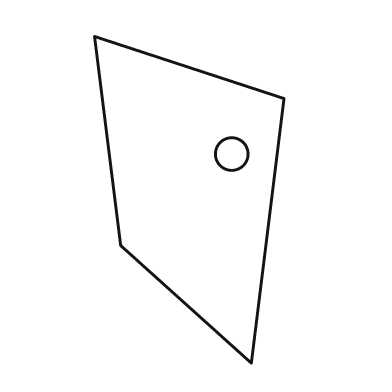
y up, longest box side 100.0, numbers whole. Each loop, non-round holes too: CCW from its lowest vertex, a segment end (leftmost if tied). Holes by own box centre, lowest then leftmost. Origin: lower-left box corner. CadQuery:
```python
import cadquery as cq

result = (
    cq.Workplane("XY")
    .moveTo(48.0, 0.0)
    .lineTo(58.0, 81.0)
    .lineTo(0.0, 100.0)
    .lineTo(8.0, 36.0)
    .close()
    .moveTo(42.0, 64.0)
    .circle(5.0)
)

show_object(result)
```